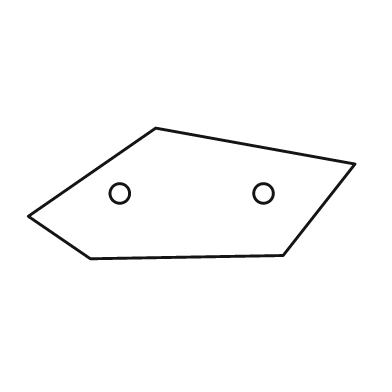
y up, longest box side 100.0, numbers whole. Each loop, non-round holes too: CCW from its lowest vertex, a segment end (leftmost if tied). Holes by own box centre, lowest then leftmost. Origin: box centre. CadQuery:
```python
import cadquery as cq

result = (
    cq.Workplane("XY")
    .moveTo(-31.0, -20.0)
    .lineTo(28.0, -19.0)
    .lineTo(50.0, 9.0)
    .lineTo(-11.0, 20.0)
    .lineTo(-50.0, -7.0)
    .close()
    .moveTo(-22.0, 0.0)
    .circle(3.0)
    .moveTo(22.0, 0.0)
    .circle(3.0)
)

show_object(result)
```